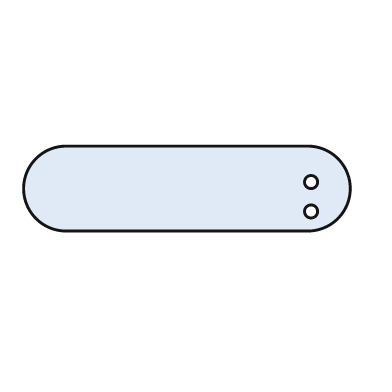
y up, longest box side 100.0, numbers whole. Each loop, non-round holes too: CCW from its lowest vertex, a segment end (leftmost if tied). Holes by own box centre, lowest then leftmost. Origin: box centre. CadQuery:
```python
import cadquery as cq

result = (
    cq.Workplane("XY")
    .moveTo(-37.0, -13.0)
    .lineTo(37.0, -13.0)
    .threePointArc((50.0, 0.0), (37.0, 13.0))
    .lineTo(-37.0, 13.0)
    .threePointArc((-50.0, 0.0), (-37.0, -13.0))
    .close()
    .moveTo(38.0, -7.0)
    .circle(2.0)
    .moveTo(38.0, 2.0)
    .circle(2.0)
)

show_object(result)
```